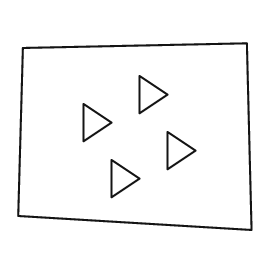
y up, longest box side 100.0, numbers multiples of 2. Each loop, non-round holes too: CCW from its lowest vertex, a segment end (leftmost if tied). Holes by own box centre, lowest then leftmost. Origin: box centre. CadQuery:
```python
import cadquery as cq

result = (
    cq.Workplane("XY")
    .moveTo(50.0, -40.0)
    .lineTo(48.0, 40.0)
    .lineTo(-48.0, 38.0)
    .lineTo(-50.0, -34.0)
    .close()
    .moveTo(-10.0, -26.0)
    .lineTo(2.0, -18.0)
    .lineTo(-10.0, -10.0)
    .close()
    .moveTo(14.0, -14.0)
    .lineTo(26.0, -6.0)
    .lineTo(14.0, 2.0)
    .close()
    .moveTo(-22.0, -2.0)
    .lineTo(-10.0, 6.0)
    .lineTo(-22.0, 14.0)
    .close()
    .moveTo(2.0, 10.0)
    .lineTo(14.0, 18.0)
    .lineTo(2.0, 26.0)
    .close()
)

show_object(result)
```